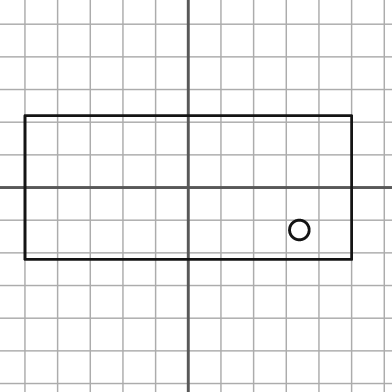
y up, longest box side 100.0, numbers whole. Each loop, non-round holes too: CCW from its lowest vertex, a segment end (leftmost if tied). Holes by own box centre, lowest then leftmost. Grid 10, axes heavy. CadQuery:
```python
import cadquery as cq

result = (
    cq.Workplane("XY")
    .moveTo(-50.0, -22.0)
    .lineTo(50.0, -22.0)
    .lineTo(50.0, 22.0)
    .lineTo(-50.0, 22.0)
    .close()
    .moveTo(34.0, -13.0)
    .circle(3.0)
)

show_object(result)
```